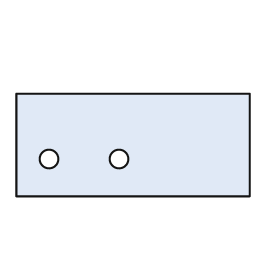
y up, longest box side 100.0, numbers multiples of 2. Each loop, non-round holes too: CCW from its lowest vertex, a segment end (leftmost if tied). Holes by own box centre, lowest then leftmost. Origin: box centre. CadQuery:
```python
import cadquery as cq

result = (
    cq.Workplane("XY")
    .moveTo(-50.0, -22.0)
    .lineTo(50.0, -22.0)
    .lineTo(50.0, 22.0)
    .lineTo(-50.0, 22.0)
    .close()
    .moveTo(-36.0, -6.0)
    .circle(4.0)
    .moveTo(-6.0, -6.0)
    .circle(4.0)
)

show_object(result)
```